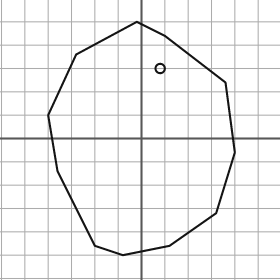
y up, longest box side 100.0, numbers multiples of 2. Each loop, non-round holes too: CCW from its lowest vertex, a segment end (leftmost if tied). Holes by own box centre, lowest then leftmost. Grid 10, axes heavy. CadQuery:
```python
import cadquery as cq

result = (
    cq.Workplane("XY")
    .moveTo(-8.0, -50.0)
    .lineTo(12.0, -46.0)
    .lineTo(32.0, -32.0)
    .lineTo(40.0, -6.0)
    .lineTo(36.0, 24.0)
    .lineTo(10.0, 44.0)
    .lineTo(-2.0, 50.0)
    .lineTo(-28.0, 36.0)
    .lineTo(-40.0, 10.0)
    .lineTo(-36.0, -14.0)
    .lineTo(-20.0, -46.0)
    .close()
    .moveTo(8.0, 30.0)
    .circle(2.0)
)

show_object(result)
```